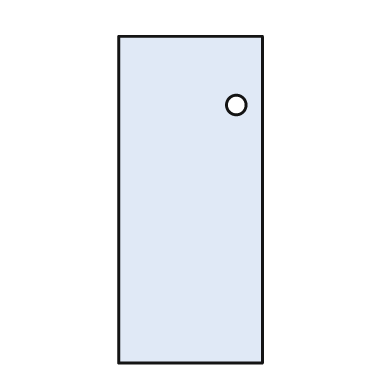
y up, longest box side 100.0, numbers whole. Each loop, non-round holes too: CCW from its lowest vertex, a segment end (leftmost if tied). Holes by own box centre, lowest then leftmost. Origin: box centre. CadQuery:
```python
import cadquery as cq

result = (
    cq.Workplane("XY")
    .moveTo(-22.0, -50.0)
    .lineTo(22.0, -50.0)
    .lineTo(22.0, 50.0)
    .lineTo(-22.0, 50.0)
    .close()
    .moveTo(14.0, 29.0)
    .circle(3.0)
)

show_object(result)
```